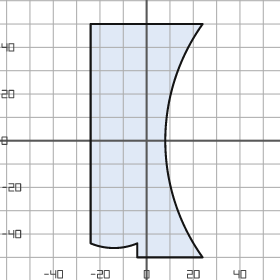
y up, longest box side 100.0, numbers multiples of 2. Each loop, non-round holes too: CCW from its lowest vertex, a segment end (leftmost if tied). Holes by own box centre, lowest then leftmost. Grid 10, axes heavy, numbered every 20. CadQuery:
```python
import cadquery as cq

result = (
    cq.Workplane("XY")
    .moveTo(-4.0, -50.0)
    .lineTo(24.0, -50.0)
    .threePointArc((8.0, 0.0), (24.0, 50.0))
    .lineTo(-24.0, 50.0)
    .lineTo(-24.0, -44.0)
    .threePointArc((-14.0, -46.0), (-4.0, -44.0))
    .close()
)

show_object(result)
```